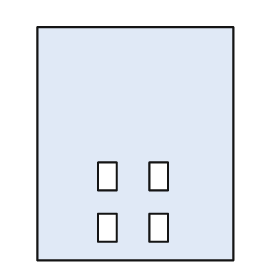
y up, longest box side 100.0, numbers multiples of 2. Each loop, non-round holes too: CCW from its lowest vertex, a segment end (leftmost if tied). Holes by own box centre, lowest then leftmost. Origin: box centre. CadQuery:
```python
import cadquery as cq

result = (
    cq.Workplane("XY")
    .moveTo(-42.0, -50.0)
    .lineTo(42.0, -50.0)
    .lineTo(42.0, 50.0)
    .lineTo(-42.0, 50.0)
    .close()
    .moveTo(-16.0, -42.0)
    .lineTo(-8.0, -42.0)
    .lineTo(-8.0, -30.0)
    .lineTo(-16.0, -30.0)
    .close()
    .moveTo(6.0, -42.0)
    .lineTo(14.0, -42.0)
    .lineTo(14.0, -30.0)
    .lineTo(6.0, -30.0)
    .close()
    .moveTo(-16.0, -20.0)
    .lineTo(-8.0, -20.0)
    .lineTo(-8.0, -8.0)
    .lineTo(-16.0, -8.0)
    .close()
    .moveTo(6.0, -20.0)
    .lineTo(14.0, -20.0)
    .lineTo(14.0, -8.0)
    .lineTo(6.0, -8.0)
    .close()
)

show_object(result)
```